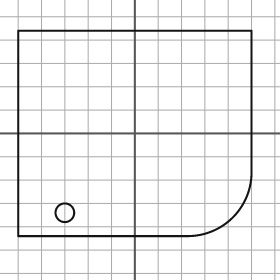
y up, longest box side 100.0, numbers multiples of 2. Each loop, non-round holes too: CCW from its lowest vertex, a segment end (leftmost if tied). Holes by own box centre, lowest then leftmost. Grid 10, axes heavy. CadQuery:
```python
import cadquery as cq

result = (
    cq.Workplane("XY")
    .moveTo(-50.0, -44.0)
    .lineTo(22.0, -44.0)
    .threePointArc((42.0, -36.0), (50.0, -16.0))
    .lineTo(50.0, 44.0)
    .lineTo(-50.0, 44.0)
    .close()
    .moveTo(-30.0, -34.0)
    .circle(4.0)
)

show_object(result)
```